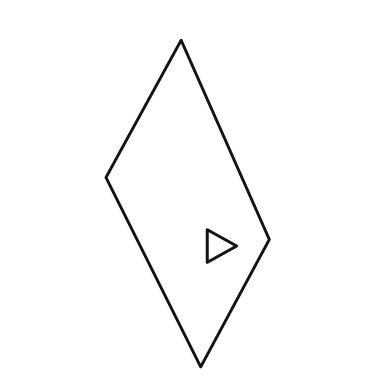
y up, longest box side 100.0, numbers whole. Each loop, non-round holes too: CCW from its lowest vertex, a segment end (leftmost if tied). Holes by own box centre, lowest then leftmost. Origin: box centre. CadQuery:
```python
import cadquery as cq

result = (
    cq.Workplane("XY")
    .moveTo(4.0, -50.0)
    .lineTo(25.0, -11.0)
    .lineTo(-2.0, 50.0)
    .lineTo(-25.0, 8.0)
    .close()
    .moveTo(6.0, -18.0)
    .lineTo(15.0, -13.0)
    .lineTo(6.0, -8.0)
    .close()
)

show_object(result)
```